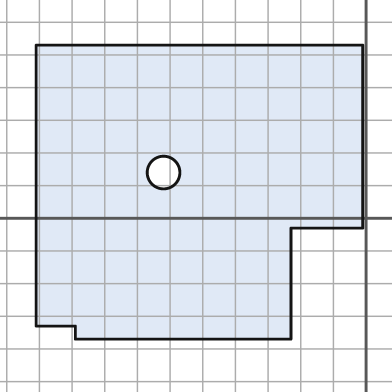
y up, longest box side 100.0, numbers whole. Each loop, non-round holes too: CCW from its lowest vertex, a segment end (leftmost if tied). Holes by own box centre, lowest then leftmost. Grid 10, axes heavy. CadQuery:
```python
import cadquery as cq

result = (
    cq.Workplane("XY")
    .moveTo(-89.0, -37.0)
    .lineTo(-23.0, -37.0)
    .lineTo(-23.0, -3.0)
    .lineTo(-1.0, -3.0)
    .lineTo(-1.0, 53.0)
    .lineTo(-101.0, 53.0)
    .lineTo(-101.0, -33.0)
    .lineTo(-89.0, -33.0)
    .close()
    .moveTo(-62.0, 14.0)
    .circle(5.0)
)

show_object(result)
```